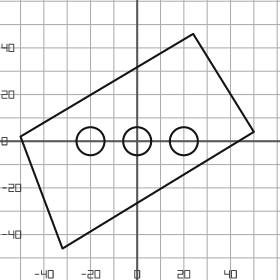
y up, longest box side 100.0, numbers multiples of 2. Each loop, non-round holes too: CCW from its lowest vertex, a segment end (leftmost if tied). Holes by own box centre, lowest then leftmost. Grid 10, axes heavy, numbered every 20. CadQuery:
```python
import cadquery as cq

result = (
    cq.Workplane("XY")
    .moveTo(-32.0, -46.0)
    .lineTo(50.0, 4.0)
    .lineTo(24.0, 46.0)
    .lineTo(-50.0, 2.0)
    .close()
    .moveTo(-20.0, 0.0)
    .circle(6.0)
    .moveTo(0.0, 0.0)
    .circle(6.0)
    .moveTo(20.0, 0.0)
    .circle(6.0)
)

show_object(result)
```